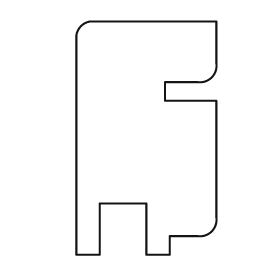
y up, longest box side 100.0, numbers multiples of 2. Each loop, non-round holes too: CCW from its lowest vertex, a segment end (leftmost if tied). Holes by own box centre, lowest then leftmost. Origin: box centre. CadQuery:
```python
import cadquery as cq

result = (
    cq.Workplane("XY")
    .moveTo(-30.0, -50.0)
    .lineTo(-20.0, -50.0)
    .lineTo(-20.0, -28.0)
    .lineTo(0.0, -28.0)
    .lineTo(0.0, -50.0)
    .lineTo(10.0, -50.0)
    .lineTo(10.0, -42.0)
    .lineTo(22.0, -42.0)
    .threePointArc((28.0, -40.0), (30.0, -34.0))
    .lineTo(30.0, 16.0)
    .lineTo(8.0, 16.0)
    .lineTo(8.0, 24.0)
    .lineTo(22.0, 24.0)
    .threePointArc((28.0, 26.0), (30.0, 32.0))
    .lineTo(30.0, 50.0)
    .lineTo(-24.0, 50.0)
    .threePointArc((-28.0, 48.0), (-30.0, 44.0))
    .close()
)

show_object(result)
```